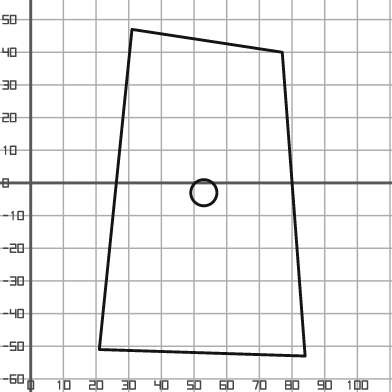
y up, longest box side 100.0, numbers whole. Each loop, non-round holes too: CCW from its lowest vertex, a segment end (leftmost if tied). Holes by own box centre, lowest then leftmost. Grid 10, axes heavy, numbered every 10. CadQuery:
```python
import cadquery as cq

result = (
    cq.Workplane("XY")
    .moveTo(84.0, -53.0)
    .lineTo(77.0, 40.0)
    .lineTo(31.0, 47.0)
    .lineTo(21.0, -51.0)
    .close()
    .moveTo(53.0, -3.0)
    .circle(4.0)
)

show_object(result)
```